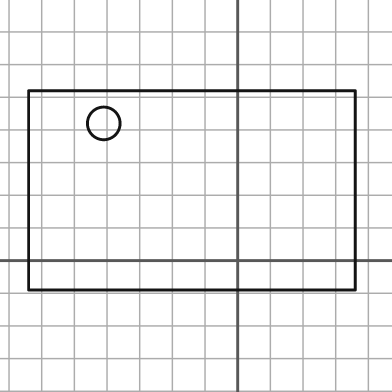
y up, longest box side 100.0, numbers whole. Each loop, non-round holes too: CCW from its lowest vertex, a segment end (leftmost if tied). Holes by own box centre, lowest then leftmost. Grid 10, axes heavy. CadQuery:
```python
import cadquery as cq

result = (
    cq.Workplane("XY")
    .moveTo(-64.0, -9.0)
    .lineTo(36.0, -9.0)
    .lineTo(36.0, 52.0)
    .lineTo(-64.0, 52.0)
    .close()
    .moveTo(-41.0, 42.0)
    .circle(5.0)
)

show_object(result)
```